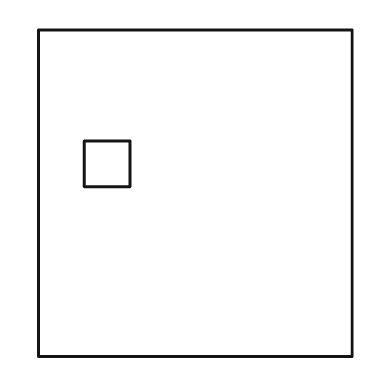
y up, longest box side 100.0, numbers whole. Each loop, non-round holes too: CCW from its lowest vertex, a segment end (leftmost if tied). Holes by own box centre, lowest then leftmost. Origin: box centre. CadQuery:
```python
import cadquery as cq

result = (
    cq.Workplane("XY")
    .moveTo(-48.0, -50.0)
    .lineTo(48.0, -50.0)
    .lineTo(48.0, 50.0)
    .lineTo(-48.0, 50.0)
    .close()
    .moveTo(-34.0, 2.0)
    .lineTo(-20.0, 2.0)
    .lineTo(-20.0, 16.0)
    .lineTo(-34.0, 16.0)
    .close()
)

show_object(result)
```